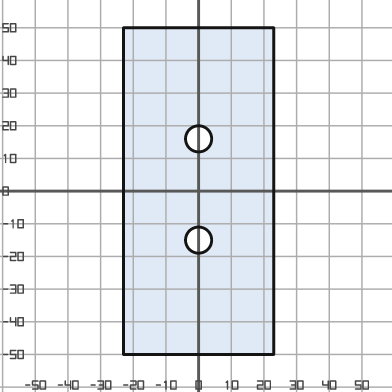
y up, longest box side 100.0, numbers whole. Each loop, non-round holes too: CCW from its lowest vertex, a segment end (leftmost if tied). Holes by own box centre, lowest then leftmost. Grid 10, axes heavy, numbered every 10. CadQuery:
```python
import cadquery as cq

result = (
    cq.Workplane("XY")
    .moveTo(-23.0, -50.0)
    .lineTo(23.0, -50.0)
    .lineTo(23.0, 50.0)
    .lineTo(-23.0, 50.0)
    .close()
    .moveTo(0.0, -15.0)
    .circle(4.0)
    .moveTo(0.0, 16.0)
    .circle(4.0)
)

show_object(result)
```